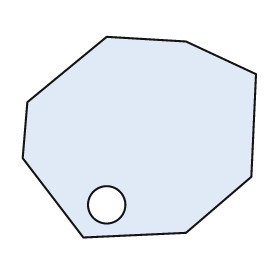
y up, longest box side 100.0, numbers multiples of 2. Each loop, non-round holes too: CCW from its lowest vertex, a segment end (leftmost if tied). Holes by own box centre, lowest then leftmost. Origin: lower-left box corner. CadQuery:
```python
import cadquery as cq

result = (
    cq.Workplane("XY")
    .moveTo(26.0, 0.0)
    .lineTo(70.0, 2.0)
    .lineTo(98.0, 26.0)
    .lineTo(100.0, 70.0)
    .lineTo(70.0, 84.0)
    .lineTo(36.0, 86.0)
    .lineTo(2.0, 58.0)
    .lineTo(0.0, 34.0)
    .close()
    .moveTo(36.0, 14.0)
    .circle(8.0)
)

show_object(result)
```